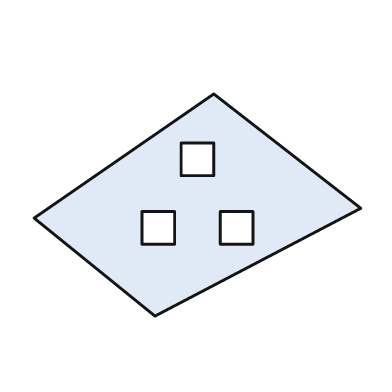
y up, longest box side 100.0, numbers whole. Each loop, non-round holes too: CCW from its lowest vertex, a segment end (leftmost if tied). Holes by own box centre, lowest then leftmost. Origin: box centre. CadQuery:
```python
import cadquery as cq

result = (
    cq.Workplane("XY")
    .moveTo(-13.0, -34.0)
    .lineTo(50.0, -1.0)
    .lineTo(5.0, 34.0)
    .lineTo(-50.0, -4.0)
    .close()
    .moveTo(-17.0, -12.0)
    .lineTo(-7.0, -12.0)
    .lineTo(-7.0, -2.0)
    .lineTo(-17.0, -2.0)
    .close()
    .moveTo(7.0, -12.0)
    .lineTo(17.0, -12.0)
    .lineTo(17.0, -2.0)
    .lineTo(7.0, -2.0)
    .close()
    .moveTo(-5.0, 9.0)
    .lineTo(5.0, 9.0)
    .lineTo(5.0, 19.0)
    .lineTo(-5.0, 19.0)
    .close()
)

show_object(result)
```